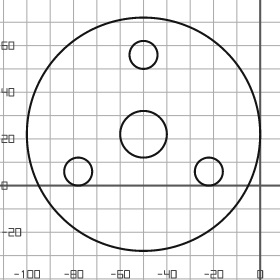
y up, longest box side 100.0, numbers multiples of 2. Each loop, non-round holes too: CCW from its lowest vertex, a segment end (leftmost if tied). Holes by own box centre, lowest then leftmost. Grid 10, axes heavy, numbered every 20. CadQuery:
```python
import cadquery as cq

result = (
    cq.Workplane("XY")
    .moveTo(-50.0, 22.0)
    .circle(50.0)
    .moveTo(-78.0, 6.0)
    .circle(6.0)
    .moveTo(-22.0, 6.0)
    .circle(6.0)
    .moveTo(-50.0, 22.0)
    .circle(10.0)
    .moveTo(-50.0, 56.0)
    .circle(6.0)
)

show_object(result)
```